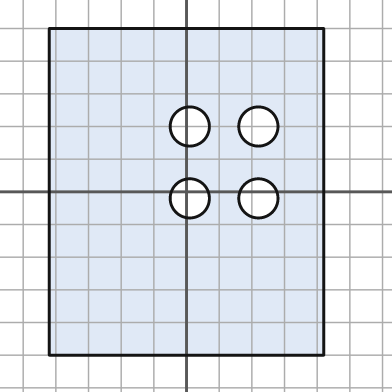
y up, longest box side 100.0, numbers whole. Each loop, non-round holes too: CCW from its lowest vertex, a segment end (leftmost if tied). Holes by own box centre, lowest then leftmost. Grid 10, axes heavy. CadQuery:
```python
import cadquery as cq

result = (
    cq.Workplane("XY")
    .moveTo(-42.0, -50.0)
    .lineTo(42.0, -50.0)
    .lineTo(42.0, 50.0)
    .lineTo(-42.0, 50.0)
    .close()
    .moveTo(1.0, -2.0)
    .circle(6.0)
    .moveTo(22.0, -2.0)
    .circle(6.0)
    .moveTo(1.0, 20.0)
    .circle(6.0)
    .moveTo(22.0, 20.0)
    .circle(6.0)
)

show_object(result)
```